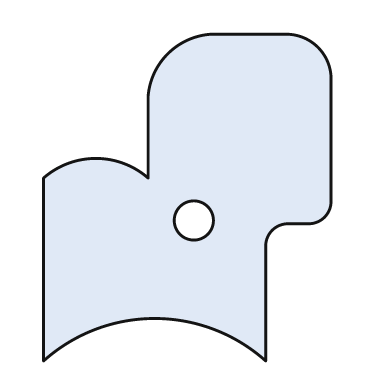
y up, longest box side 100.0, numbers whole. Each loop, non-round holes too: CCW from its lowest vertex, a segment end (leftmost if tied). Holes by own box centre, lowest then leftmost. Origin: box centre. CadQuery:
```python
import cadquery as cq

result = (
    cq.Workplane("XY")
    .moveTo(-44.0, -50.0)
    .threePointArc((-10.0, -37.0), (24.0, -50.0))
    .lineTo(24.0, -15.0)
    .threePointArc((26.0, -10.0), (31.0, -8.0))
    .lineTo(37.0, -8.0)
    .threePointArc((42.0, -6.0), (44.0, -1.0))
    .lineTo(44.0, 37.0)
    .threePointArc((40.0, 46.0), (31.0, 50.0))
    .lineTo(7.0, 50.0)
    .threePointArc((-6.0, 44.0), (-12.0, 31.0))
    .lineTo(-12.0, 6.0)
    .threePointArc((-28.0, 12.0), (-44.0, 6.0))
    .close()
    .moveTo(2.0, -7.0)
    .circle(6.0)
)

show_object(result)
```